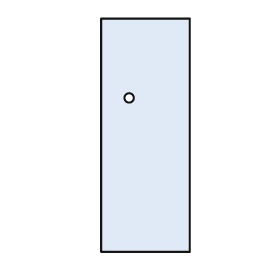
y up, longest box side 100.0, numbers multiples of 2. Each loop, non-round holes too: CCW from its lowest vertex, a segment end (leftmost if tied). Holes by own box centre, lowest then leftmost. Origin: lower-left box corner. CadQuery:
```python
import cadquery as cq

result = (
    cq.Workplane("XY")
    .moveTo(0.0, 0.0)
    .lineTo(38.0, 0.0)
    .lineTo(38.0, 100.0)
    .lineTo(0.0, 100.0)
    .close()
    .moveTo(12.0, 66.0)
    .circle(2.0)
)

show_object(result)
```